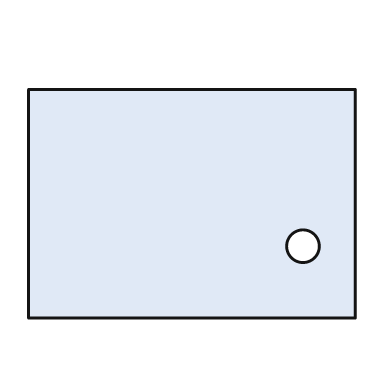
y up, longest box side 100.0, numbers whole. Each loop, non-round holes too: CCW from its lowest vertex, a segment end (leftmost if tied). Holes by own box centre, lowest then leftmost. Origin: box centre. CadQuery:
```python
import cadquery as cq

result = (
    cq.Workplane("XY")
    .moveTo(-50.0, -35.0)
    .lineTo(50.0, -35.0)
    .lineTo(50.0, 35.0)
    .lineTo(-50.0, 35.0)
    .close()
    .moveTo(34.0, -13.0)
    .circle(5.0)
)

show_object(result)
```